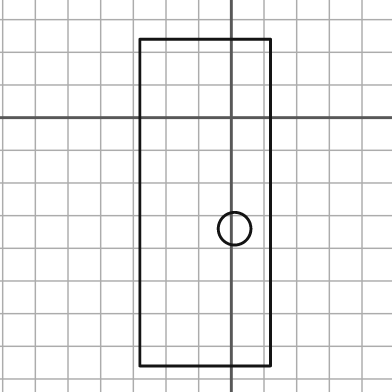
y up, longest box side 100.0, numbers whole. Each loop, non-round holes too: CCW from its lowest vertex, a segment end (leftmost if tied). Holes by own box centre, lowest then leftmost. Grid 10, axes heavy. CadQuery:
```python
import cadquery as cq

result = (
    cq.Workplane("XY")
    .moveTo(-28.0, -76.0)
    .lineTo(12.0, -76.0)
    .lineTo(12.0, 24.0)
    .lineTo(-28.0, 24.0)
    .close()
    .moveTo(1.0, -34.0)
    .circle(5.0)
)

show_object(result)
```